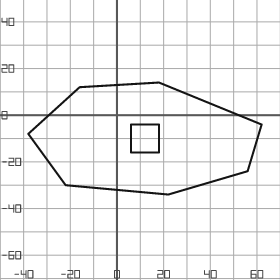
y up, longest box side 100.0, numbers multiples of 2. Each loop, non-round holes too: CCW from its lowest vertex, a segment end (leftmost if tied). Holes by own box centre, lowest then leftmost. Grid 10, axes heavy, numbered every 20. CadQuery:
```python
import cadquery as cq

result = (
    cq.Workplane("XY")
    .moveTo(22.0, -34.0)
    .lineTo(56.0, -24.0)
    .lineTo(62.0, -4.0)
    .lineTo(18.0, 14.0)
    .lineTo(-16.0, 12.0)
    .lineTo(-38.0, -8.0)
    .lineTo(-22.0, -30.0)
    .close()
    .moveTo(6.0, -16.0)
    .lineTo(18.0, -16.0)
    .lineTo(18.0, -4.0)
    .lineTo(6.0, -4.0)
    .close()
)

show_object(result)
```